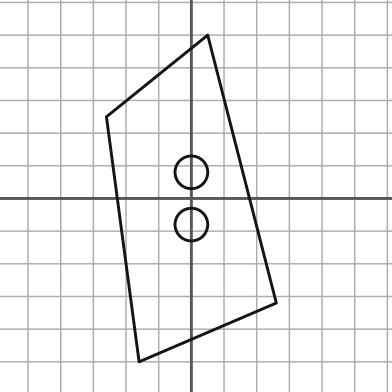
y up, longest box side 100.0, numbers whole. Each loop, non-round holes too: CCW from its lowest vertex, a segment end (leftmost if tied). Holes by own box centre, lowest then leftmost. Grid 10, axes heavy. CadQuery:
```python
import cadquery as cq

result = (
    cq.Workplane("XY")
    .moveTo(-16.0, -50.0)
    .lineTo(26.0, -32.0)
    .lineTo(5.0, 50.0)
    .lineTo(-26.0, 25.0)
    .close()
    .moveTo(0.0, -8.0)
    .circle(5.0)
    .moveTo(0.0, 8.0)
    .circle(5.0)
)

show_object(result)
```